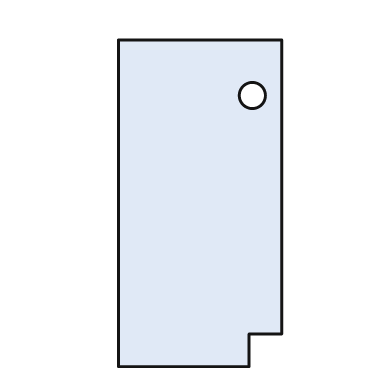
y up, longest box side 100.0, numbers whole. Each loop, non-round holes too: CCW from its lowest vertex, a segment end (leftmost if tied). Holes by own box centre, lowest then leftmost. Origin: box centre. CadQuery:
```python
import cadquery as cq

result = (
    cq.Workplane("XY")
    .moveTo(-25.0, -50.0)
    .lineTo(15.0, -50.0)
    .lineTo(15.0, -40.0)
    .lineTo(25.0, -40.0)
    .lineTo(25.0, 50.0)
    .lineTo(-25.0, 50.0)
    .close()
    .moveTo(16.0, 33.0)
    .circle(4.0)
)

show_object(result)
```